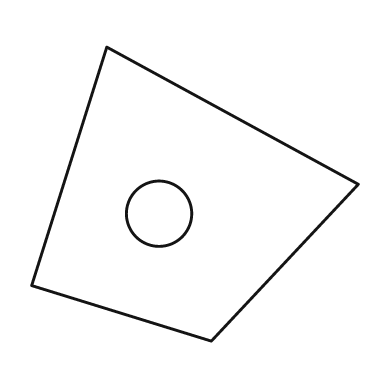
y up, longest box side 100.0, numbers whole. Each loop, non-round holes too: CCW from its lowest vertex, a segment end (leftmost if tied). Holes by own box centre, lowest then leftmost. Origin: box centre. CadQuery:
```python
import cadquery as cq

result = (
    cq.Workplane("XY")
    .moveTo(5.0, -45.0)
    .lineTo(50.0, 3.0)
    .lineTo(-27.0, 45.0)
    .lineTo(-50.0, -28.0)
    .close()
    .moveTo(-11.0, -6.0)
    .circle(10.0)
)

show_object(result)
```